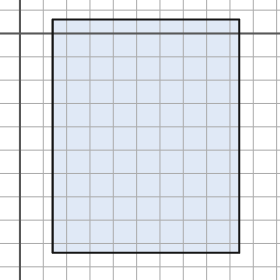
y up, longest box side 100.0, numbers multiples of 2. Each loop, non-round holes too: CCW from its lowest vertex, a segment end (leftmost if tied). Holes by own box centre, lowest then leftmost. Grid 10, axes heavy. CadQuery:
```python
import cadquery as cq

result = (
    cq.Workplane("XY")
    .moveTo(14.0, -94.0)
    .lineTo(94.0, -94.0)
    .lineTo(94.0, 6.0)
    .lineTo(14.0, 6.0)
    .close()
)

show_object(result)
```